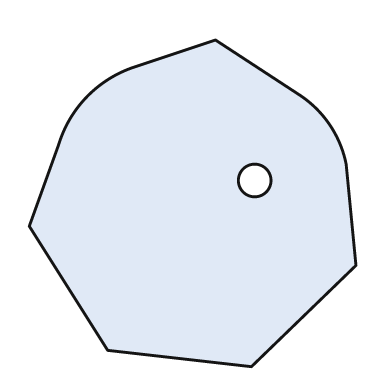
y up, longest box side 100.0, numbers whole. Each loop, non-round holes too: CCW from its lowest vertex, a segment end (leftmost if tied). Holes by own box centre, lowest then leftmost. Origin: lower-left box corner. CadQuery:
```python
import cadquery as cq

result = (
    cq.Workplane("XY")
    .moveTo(68.0, 0.0)
    .lineTo(100.0, 31.0)
    .lineTo(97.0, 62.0)
    .threePointArc((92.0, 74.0), (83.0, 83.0))
    .lineTo(57.0, 100.0)
    .lineTo(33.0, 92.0)
    .threePointArc((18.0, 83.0), (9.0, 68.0))
    .lineTo(0.0, 43.0)
    .lineTo(24.0, 5.0)
    .close()
    .moveTo(69.0, 57.0)
    .circle(5.0)
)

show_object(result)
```